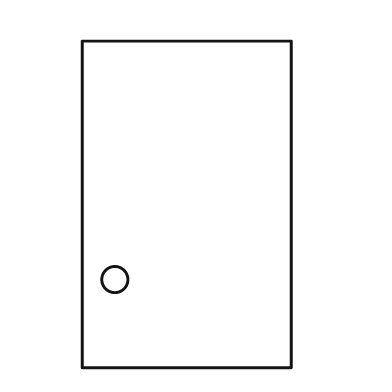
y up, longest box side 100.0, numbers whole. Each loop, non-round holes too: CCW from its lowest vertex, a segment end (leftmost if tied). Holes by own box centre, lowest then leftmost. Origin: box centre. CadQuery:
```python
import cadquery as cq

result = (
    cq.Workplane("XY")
    .moveTo(-32.0, -50.0)
    .lineTo(32.0, -50.0)
    .lineTo(32.0, 50.0)
    .lineTo(-32.0, 50.0)
    .close()
    .moveTo(-22.0, -23.0)
    .circle(4.0)
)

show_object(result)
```